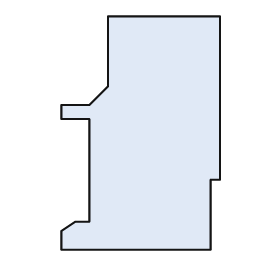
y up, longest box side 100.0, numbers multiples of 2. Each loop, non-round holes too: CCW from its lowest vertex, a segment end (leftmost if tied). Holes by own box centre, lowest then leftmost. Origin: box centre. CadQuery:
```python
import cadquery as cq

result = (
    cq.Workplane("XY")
    .moveTo(-34.0, -50.0)
    .lineTo(30.0, -50.0)
    .lineTo(30.0, -20.0)
    .lineTo(34.0, -20.0)
    .lineTo(34.0, 50.0)
    .lineTo(-14.0, 50.0)
    .lineTo(-14.0, 20.0)
    .lineTo(-22.0, 12.0)
    .lineTo(-34.0, 12.0)
    .lineTo(-34.0, 6.0)
    .lineTo(-22.0, 6.0)
    .lineTo(-22.0, -38.0)
    .lineTo(-28.0, -38.0)
    .lineTo(-34.0, -42.0)
    .close()
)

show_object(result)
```